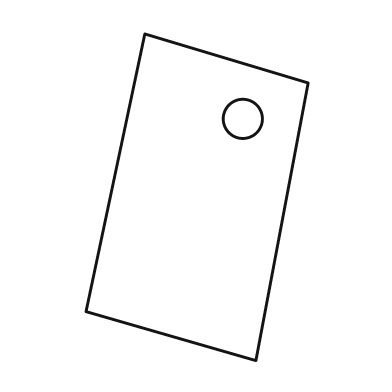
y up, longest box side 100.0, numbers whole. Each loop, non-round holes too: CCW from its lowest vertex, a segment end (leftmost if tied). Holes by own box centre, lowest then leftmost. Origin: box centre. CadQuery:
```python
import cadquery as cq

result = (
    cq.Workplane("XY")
    .moveTo(18.0, -50.0)
    .lineTo(34.0, 35.0)
    .lineTo(-16.0, 50.0)
    .lineTo(-34.0, -35.0)
    .close()
    .moveTo(14.0, 24.0)
    .circle(6.0)
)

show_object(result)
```